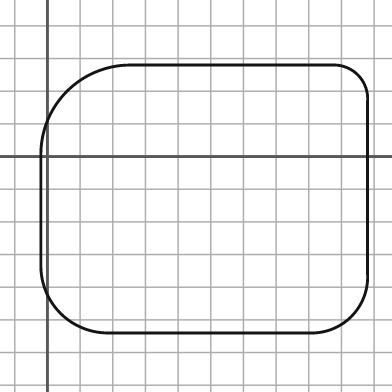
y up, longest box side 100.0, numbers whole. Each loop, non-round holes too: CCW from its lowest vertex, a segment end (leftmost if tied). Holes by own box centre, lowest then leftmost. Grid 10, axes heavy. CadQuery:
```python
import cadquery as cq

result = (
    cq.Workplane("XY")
    .moveTo(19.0, -54.0)
    .lineTo(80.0, -54.0)
    .threePointArc((93.0, -49.0), (98.0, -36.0))
    .lineTo(98.0, 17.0)
    .threePointArc((95.0, 25.0), (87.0, 28.0))
    .lineTo(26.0, 28.0)
    .threePointArc((6.0, 20.0), (-2.0, 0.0))
    .lineTo(-2.0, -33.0)
    .threePointArc((4.0, -48.0), (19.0, -54.0))
    .close()
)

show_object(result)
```